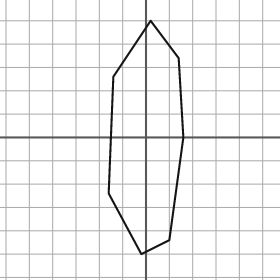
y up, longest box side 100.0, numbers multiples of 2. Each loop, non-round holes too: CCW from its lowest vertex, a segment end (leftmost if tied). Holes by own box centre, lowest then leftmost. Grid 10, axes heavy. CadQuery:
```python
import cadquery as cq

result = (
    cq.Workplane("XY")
    .moveTo(-2.0, -50.0)
    .lineTo(10.0, -44.0)
    .lineTo(16.0, 0.0)
    .lineTo(14.0, 34.0)
    .lineTo(2.0, 50.0)
    .lineTo(-14.0, 26.0)
    .lineTo(-16.0, -24.0)
    .close()
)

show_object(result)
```